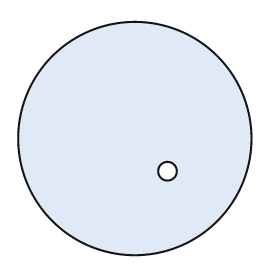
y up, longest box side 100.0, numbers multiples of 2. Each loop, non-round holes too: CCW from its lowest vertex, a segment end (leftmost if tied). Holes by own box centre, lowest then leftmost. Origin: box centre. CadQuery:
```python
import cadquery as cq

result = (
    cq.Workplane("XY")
    .moveTo(0.0, 0.0)
    .circle(50.0)
    .moveTo(14.0, -14.0)
    .circle(4.0)
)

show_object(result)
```